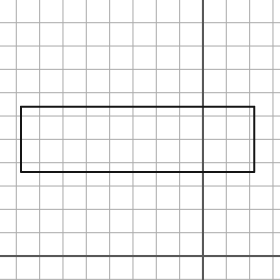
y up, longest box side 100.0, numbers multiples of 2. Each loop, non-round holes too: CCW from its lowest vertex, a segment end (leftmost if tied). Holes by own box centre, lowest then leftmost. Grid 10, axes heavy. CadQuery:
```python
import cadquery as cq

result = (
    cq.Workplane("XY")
    .moveTo(-78.0, 36.0)
    .lineTo(22.0, 36.0)
    .lineTo(22.0, 64.0)
    .lineTo(-78.0, 64.0)
    .close()
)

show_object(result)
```